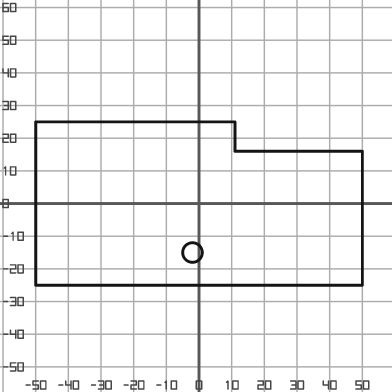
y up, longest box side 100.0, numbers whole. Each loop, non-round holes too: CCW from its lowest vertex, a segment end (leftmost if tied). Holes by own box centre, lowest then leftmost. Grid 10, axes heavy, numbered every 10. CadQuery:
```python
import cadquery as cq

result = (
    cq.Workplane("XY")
    .moveTo(-50.0, -25.0)
    .lineTo(50.0, -25.0)
    .lineTo(50.0, 16.0)
    .lineTo(11.0, 16.0)
    .lineTo(11.0, 25.0)
    .lineTo(-50.0, 25.0)
    .close()
    .moveTo(-2.0, -15.0)
    .circle(3.0)
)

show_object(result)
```